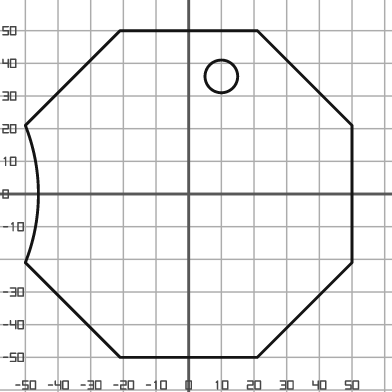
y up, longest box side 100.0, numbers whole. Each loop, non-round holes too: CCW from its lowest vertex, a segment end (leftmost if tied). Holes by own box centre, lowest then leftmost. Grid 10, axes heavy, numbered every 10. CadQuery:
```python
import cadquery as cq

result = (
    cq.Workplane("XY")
    .moveTo(-21.0, -50.0)
    .lineTo(21.0, -50.0)
    .lineTo(50.0, -21.0)
    .lineTo(50.0, 21.0)
    .lineTo(21.0, 50.0)
    .lineTo(-21.0, 50.0)
    .lineTo(-50.0, 21.0)
    .threePointArc((-46.0, 0.0), (-50.0, -21.0))
    .close()
    .moveTo(10.0, 36.0)
    .circle(5.0)
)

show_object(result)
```